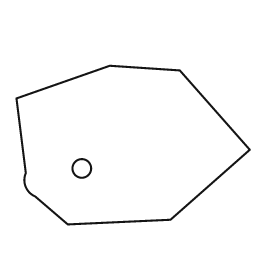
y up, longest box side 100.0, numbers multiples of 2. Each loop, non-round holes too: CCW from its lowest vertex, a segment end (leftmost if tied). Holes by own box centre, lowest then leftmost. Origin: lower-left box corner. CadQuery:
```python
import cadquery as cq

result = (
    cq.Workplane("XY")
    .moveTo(22.0, 0.0)
    .lineTo(66.0, 2.0)
    .lineTo(100.0, 32.0)
    .lineTo(70.0, 66.0)
    .lineTo(40.0, 68.0)
    .lineTo(0.0, 54.0)
    .lineTo(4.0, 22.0)
    .threePointArc((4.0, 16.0), (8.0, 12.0))
    .close()
    .moveTo(28.0, 24.0)
    .circle(4.0)
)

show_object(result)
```